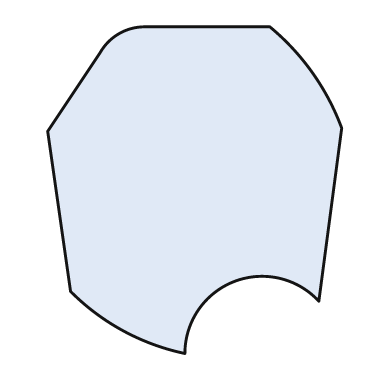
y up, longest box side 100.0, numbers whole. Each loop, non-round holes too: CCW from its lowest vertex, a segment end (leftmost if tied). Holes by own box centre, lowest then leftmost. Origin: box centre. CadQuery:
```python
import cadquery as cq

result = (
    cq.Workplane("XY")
    .moveTo(-3.0, -50.0)
    .threePointArc((12.0, -28.0), (38.0, -34.0))
    .lineTo(45.0, 19.0)
    .threePointArc((36.0, 36.0), (23.0, 50.0))
    .lineTo(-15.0, 50.0)
    .threePointArc((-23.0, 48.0), (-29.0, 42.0))
    .lineTo(-45.0, 18.0)
    .lineTo(-38.0, -31.0)
    .threePointArc((-22.0, -43.0), (-3.0, -50.0))
    .close()
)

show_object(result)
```